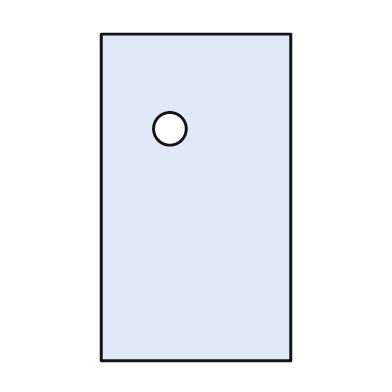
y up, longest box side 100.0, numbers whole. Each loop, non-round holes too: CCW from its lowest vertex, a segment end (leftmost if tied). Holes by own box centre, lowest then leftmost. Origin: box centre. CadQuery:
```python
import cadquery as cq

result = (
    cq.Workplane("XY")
    .moveTo(-29.0, -50.0)
    .lineTo(29.0, -50.0)
    .lineTo(29.0, 50.0)
    .lineTo(-29.0, 50.0)
    .close()
    .moveTo(-8.0, 21.0)
    .circle(5.0)
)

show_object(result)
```